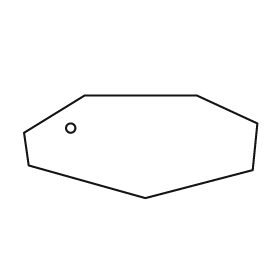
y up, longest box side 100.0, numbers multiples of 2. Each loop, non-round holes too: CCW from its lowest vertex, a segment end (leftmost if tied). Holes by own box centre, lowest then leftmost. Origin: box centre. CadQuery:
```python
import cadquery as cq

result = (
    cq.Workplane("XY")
    .moveTo(2.0, -22.0)
    .lineTo(48.0, -10.0)
    .lineTo(50.0, 10.0)
    .lineTo(24.0, 22.0)
    .lineTo(-24.0, 22.0)
    .lineTo(-50.0, 6.0)
    .lineTo(-48.0, -8.0)
    .close()
    .moveTo(-30.0, 8.0)
    .circle(2.0)
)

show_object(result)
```